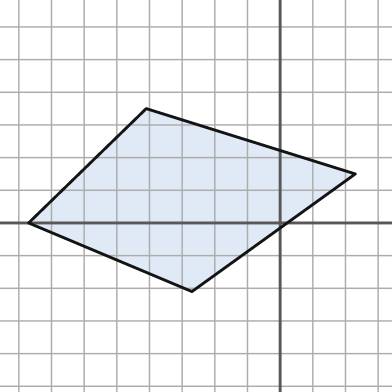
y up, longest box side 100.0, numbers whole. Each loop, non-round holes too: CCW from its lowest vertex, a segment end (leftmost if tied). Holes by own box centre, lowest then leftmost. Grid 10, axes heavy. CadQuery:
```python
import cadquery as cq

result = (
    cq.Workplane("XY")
    .moveTo(-27.0, -21.0)
    .lineTo(23.0, 15.0)
    .lineTo(-41.0, 35.0)
    .lineTo(-77.0, 0.0)
    .close()
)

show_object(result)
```